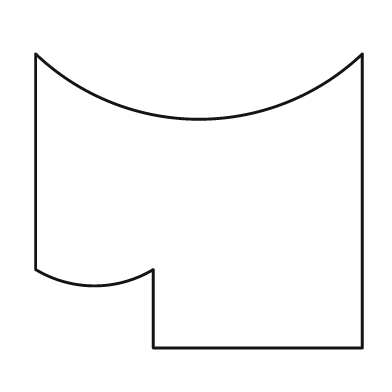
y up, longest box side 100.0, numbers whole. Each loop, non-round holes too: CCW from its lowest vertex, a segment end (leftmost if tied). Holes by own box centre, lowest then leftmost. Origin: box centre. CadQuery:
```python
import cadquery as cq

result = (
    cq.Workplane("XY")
    .moveTo(-14.0, -45.0)
    .lineTo(50.0, -45.0)
    .lineTo(50.0, 45.0)
    .threePointArc((0.0, 25.0), (-50.0, 45.0))
    .lineTo(-50.0, -21.0)
    .threePointArc((-32.0, -26.0), (-14.0, -21.0))
    .close()
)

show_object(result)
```